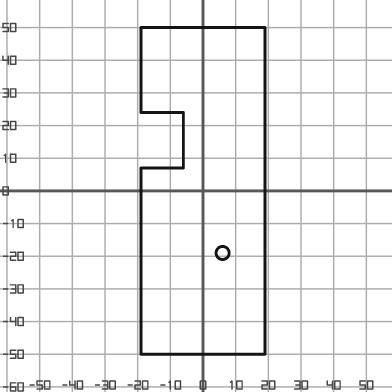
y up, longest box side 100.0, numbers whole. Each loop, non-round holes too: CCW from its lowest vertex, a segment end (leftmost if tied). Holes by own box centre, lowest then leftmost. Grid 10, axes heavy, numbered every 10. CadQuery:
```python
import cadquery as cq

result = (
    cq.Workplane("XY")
    .moveTo(-19.0, -50.0)
    .lineTo(19.0, -50.0)
    .lineTo(19.0, 50.0)
    .lineTo(-19.0, 50.0)
    .lineTo(-19.0, 24.0)
    .lineTo(-6.0, 24.0)
    .lineTo(-6.0, 7.0)
    .lineTo(-19.0, 7.0)
    .close()
    .moveTo(6.0, -19.0)
    .circle(2.0)
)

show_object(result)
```